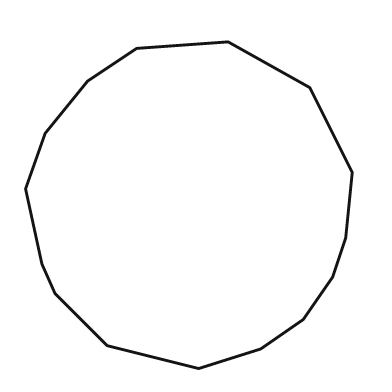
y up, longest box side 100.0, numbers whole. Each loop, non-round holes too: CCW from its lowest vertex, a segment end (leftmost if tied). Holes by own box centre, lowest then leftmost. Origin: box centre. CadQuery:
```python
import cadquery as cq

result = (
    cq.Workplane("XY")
    .moveTo(3.0, -50.0)
    .lineTo(22.0, -44.0)
    .lineTo(35.0, -35.0)
    .lineTo(44.0, -22.0)
    .lineTo(48.0, -10.0)
    .lineTo(50.0, 10.0)
    .lineTo(37.0, 36.0)
    .lineTo(12.0, 50.0)
    .lineTo(-16.0, 48.0)
    .lineTo(-31.0, 38.0)
    .lineTo(-44.0, 22.0)
    .lineTo(-50.0, 5.0)
    .lineTo(-45.0, -18.0)
    .lineTo(-41.0, -27.0)
    .lineTo(-25.0, -43.0)
    .close()
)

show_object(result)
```